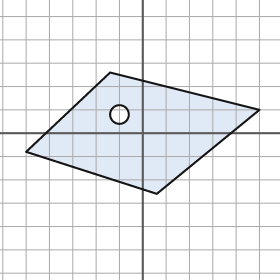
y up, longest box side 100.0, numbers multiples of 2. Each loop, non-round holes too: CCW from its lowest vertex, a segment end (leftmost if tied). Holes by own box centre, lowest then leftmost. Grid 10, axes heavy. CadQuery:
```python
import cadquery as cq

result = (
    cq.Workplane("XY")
    .moveTo(6.0, -26.0)
    .lineTo(50.0, 10.0)
    .lineTo(-14.0, 26.0)
    .lineTo(-50.0, -8.0)
    .close()
    .moveTo(-10.0, 8.0)
    .circle(4.0)
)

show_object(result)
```